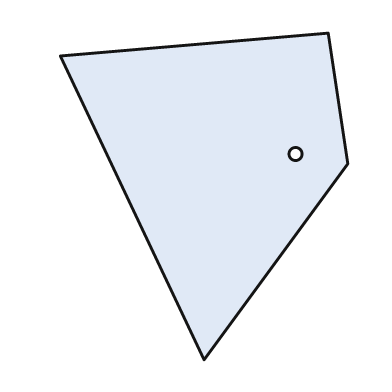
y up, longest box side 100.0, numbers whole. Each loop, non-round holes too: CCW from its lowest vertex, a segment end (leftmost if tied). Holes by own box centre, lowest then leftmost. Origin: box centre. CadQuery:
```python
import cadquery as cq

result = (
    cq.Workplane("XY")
    .moveTo(0.0, -50.0)
    .lineTo(44.0, 10.0)
    .lineTo(38.0, 50.0)
    .lineTo(-44.0, 43.0)
    .close()
    .moveTo(28.0, 13.0)
    .circle(2.0)
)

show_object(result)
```